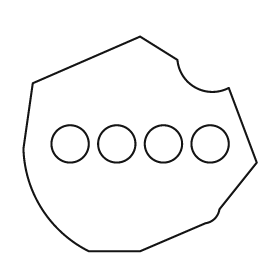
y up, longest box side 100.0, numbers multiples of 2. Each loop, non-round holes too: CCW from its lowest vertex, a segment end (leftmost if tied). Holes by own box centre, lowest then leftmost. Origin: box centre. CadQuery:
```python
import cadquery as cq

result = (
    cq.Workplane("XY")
    .moveTo(-22.0, -46.0)
    .lineTo(0.0, -46.0)
    .lineTo(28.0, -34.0)
    .threePointArc((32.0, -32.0), (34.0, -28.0))
    .lineTo(50.0, -8.0)
    .lineTo(38.0, 24.0)
    .threePointArc((24.0, 24.0), (16.0, 36.0))
    .lineTo(0.0, 46.0)
    .lineTo(-46.0, 26.0)
    .lineTo(-50.0, -2.0)
    .threePointArc((-42.0, -28.0), (-22.0, -46.0))
    .close()
    .moveTo(-30.0, 0.0)
    .circle(8.0)
    .moveTo(-10.0, 0.0)
    .circle(8.0)
    .moveTo(10.0, 0.0)
    .circle(8.0)
    .moveTo(30.0, 0.0)
    .circle(8.0)
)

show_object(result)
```